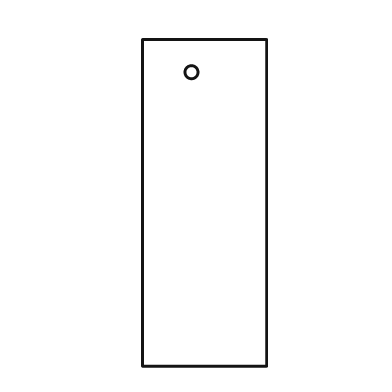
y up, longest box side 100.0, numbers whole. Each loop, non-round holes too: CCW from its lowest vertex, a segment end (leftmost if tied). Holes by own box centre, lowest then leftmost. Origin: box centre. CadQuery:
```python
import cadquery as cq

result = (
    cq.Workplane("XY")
    .moveTo(-19.0, -50.0)
    .lineTo(19.0, -50.0)
    .lineTo(19.0, 50.0)
    .lineTo(-19.0, 50.0)
    .close()
    .moveTo(-4.0, 40.0)
    .circle(2.0)
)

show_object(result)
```